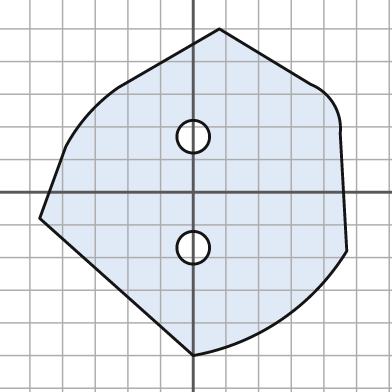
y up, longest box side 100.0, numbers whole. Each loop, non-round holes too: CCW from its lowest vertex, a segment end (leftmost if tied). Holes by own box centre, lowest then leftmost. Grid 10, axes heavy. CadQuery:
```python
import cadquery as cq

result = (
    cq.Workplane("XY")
    .moveTo(0.0, -50.0)
    .threePointArc((27.0, -39.0), (47.0, -18.0))
    .lineTo(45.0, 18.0)
    .threePointArc((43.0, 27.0), (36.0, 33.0))
    .lineTo(8.0, 50.0)
    .lineTo(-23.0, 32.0)
    .threePointArc((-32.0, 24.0), (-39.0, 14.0))
    .lineTo(-47.0, -8.0)
    .close()
    .moveTo(0.0, -17.0)
    .circle(5.0)
    .moveTo(0.0, 17.0)
    .circle(5.0)
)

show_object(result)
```